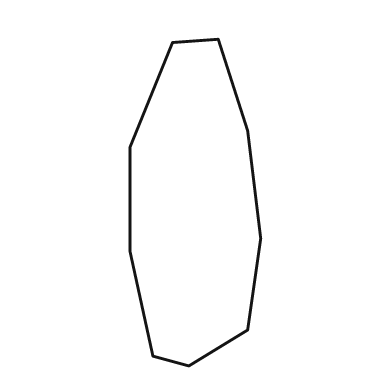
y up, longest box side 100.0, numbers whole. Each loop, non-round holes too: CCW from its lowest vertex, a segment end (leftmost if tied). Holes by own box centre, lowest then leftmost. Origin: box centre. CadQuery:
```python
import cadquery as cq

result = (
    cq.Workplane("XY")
    .moveTo(-2.0, -50.0)
    .lineTo(16.0, -39.0)
    .lineTo(20.0, -11.0)
    .lineTo(16.0, 22.0)
    .lineTo(7.0, 50.0)
    .lineTo(-7.0, 49.0)
    .lineTo(-20.0, 17.0)
    .lineTo(-20.0, -15.0)
    .lineTo(-13.0, -47.0)
    .close()
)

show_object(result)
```